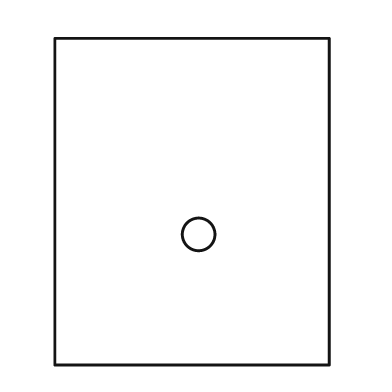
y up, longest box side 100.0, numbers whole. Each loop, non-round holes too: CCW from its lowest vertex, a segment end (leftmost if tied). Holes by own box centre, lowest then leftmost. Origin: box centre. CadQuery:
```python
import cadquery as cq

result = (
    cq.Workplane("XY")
    .moveTo(-42.0, -50.0)
    .lineTo(42.0, -50.0)
    .lineTo(42.0, 50.0)
    .lineTo(-42.0, 50.0)
    .close()
    .moveTo(2.0, -10.0)
    .circle(5.0)
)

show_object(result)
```